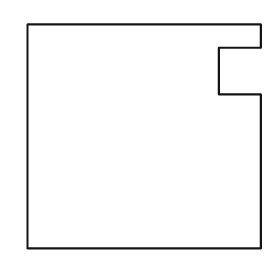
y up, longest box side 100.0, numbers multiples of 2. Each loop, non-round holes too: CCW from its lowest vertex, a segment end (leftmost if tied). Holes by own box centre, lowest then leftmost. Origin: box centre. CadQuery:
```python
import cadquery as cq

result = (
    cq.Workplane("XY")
    .moveTo(-50.0, -48.0)
    .lineTo(50.0, -48.0)
    .lineTo(50.0, 18.0)
    .lineTo(32.0, 18.0)
    .lineTo(32.0, 38.0)
    .lineTo(50.0, 38.0)
    .lineTo(50.0, 48.0)
    .lineTo(-50.0, 48.0)
    .close()
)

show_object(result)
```